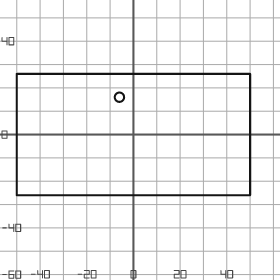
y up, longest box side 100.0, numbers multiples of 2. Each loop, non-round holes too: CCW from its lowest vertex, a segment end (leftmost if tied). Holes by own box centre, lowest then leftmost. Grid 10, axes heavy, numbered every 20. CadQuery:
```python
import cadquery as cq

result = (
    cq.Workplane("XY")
    .moveTo(-50.0, -26.0)
    .lineTo(50.0, -26.0)
    .lineTo(50.0, 26.0)
    .lineTo(-50.0, 26.0)
    .close()
    .moveTo(-6.0, 16.0)
    .circle(2.0)
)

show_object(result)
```